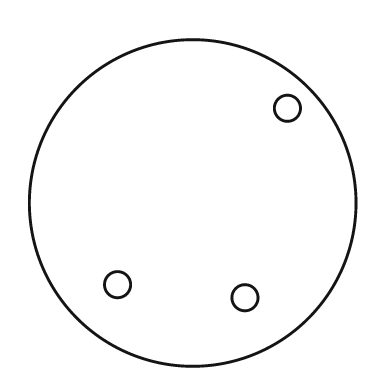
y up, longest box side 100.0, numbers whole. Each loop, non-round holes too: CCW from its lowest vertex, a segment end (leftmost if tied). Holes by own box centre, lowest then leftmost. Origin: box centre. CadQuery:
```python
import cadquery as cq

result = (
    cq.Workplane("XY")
    .moveTo(0.0, 0.0)
    .circle(50.0)
    .moveTo(16.0, -29.0)
    .circle(4.0)
    .moveTo(-23.0, -25.0)
    .circle(4.0)
    .moveTo(29.0, 29.0)
    .circle(4.0)
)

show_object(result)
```